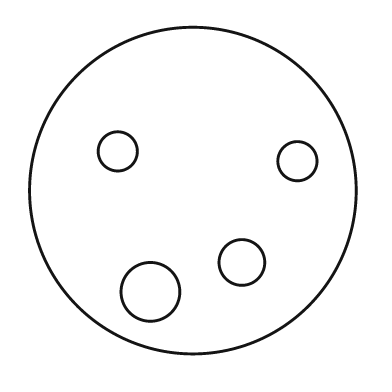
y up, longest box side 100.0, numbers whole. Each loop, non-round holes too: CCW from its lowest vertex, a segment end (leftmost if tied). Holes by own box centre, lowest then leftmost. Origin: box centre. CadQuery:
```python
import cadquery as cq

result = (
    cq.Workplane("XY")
    .moveTo(0.0, 0.0)
    .circle(50.0)
    .moveTo(-13.0, -31.0)
    .circle(9.0)
    .moveTo(15.0, -22.0)
    .circle(7.0)
    .moveTo(32.0, 9.0)
    .circle(6.0)
    .moveTo(-23.0, 12.0)
    .circle(6.0)
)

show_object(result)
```